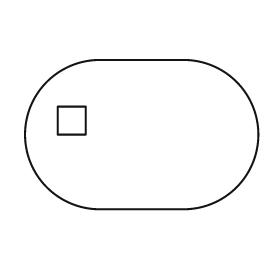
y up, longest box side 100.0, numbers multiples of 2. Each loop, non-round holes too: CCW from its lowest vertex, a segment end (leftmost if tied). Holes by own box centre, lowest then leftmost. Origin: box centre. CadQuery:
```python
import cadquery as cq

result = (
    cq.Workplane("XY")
    .moveTo(-18.0, -32.0)
    .lineTo(18.0, -32.0)
    .threePointArc((50.0, 0.0), (18.0, 32.0))
    .lineTo(-18.0, 32.0)
    .threePointArc((-50.0, 0.0), (-18.0, -32.0))
    .close()
    .moveTo(-36.0, 0.0)
    .lineTo(-24.0, 0.0)
    .lineTo(-24.0, 12.0)
    .lineTo(-36.0, 12.0)
    .close()
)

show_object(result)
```